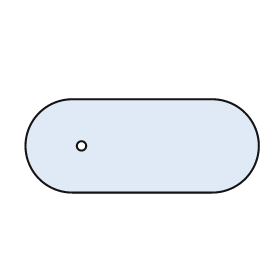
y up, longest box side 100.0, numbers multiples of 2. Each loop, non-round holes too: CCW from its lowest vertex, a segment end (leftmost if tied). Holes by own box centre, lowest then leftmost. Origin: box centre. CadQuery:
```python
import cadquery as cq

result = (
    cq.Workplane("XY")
    .moveTo(-30.0, -20.0)
    .lineTo(30.0, -20.0)
    .threePointArc((50.0, 0.0), (30.0, 20.0))
    .lineTo(-30.0, 20.0)
    .threePointArc((-50.0, 0.0), (-30.0, -20.0))
    .close()
    .moveTo(-26.0, 0.0)
    .circle(2.0)
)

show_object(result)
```